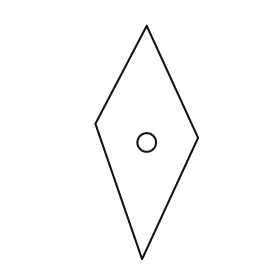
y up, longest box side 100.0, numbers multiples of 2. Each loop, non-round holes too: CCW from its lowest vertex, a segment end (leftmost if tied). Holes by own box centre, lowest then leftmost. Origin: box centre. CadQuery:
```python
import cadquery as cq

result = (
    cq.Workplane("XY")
    .moveTo(-2.0, -50.0)
    .lineTo(22.0, 2.0)
    .lineTo(0.0, 50.0)
    .lineTo(-22.0, 8.0)
    .close()
    .moveTo(0.0, 0.0)
    .circle(4.0)
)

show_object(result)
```